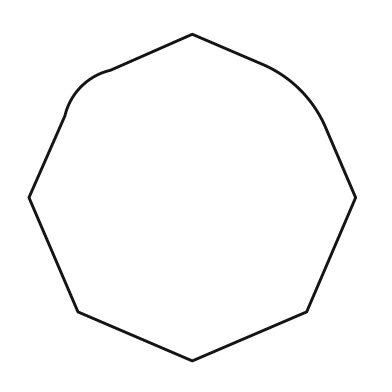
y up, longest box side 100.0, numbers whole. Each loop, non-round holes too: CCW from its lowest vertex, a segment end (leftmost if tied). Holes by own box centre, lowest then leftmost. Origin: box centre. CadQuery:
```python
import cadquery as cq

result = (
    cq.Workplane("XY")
    .moveTo(0.0, -50.0)
    .lineTo(35.0, -35.0)
    .lineTo(50.0, 0.0)
    .lineTo(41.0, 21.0)
    .threePointArc((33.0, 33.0), (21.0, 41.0))
    .lineTo(0.0, 50.0)
    .lineTo(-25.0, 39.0)
    .threePointArc((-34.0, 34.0), (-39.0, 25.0))
    .lineTo(-50.0, 0.0)
    .lineTo(-35.0, -35.0)
    .close()
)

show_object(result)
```